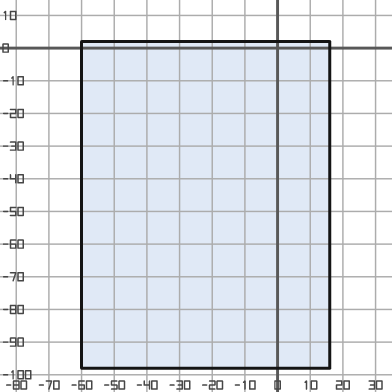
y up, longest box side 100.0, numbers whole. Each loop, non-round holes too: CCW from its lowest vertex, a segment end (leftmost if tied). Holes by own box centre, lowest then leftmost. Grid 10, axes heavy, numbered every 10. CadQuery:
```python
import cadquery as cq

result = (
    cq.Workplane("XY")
    .moveTo(-60.0, -98.0)
    .lineTo(16.0, -98.0)
    .lineTo(16.0, 2.0)
    .lineTo(-60.0, 2.0)
    .close()
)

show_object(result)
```